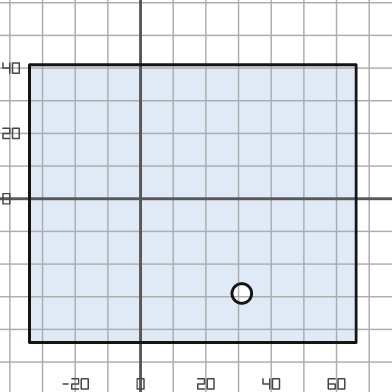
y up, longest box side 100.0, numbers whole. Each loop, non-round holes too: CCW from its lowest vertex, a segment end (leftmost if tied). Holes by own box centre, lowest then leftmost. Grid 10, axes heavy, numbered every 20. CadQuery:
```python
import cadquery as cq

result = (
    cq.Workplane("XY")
    .moveTo(-34.0, -44.0)
    .lineTo(66.0, -44.0)
    .lineTo(66.0, 41.0)
    .lineTo(-34.0, 41.0)
    .close()
    .moveTo(31.0, -29.0)
    .circle(3.0)
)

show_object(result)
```